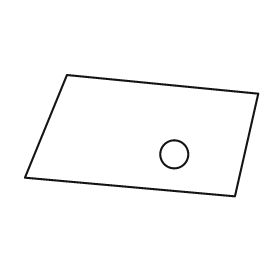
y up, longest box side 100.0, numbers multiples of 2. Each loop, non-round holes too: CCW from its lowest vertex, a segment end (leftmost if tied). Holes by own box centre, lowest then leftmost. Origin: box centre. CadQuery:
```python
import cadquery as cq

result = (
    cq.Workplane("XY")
    .moveTo(40.0, -26.0)
    .lineTo(50.0, 18.0)
    .lineTo(-32.0, 26.0)
    .lineTo(-50.0, -18.0)
    .close()
    .moveTo(14.0, -8.0)
    .circle(6.0)
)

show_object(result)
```